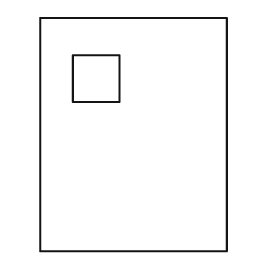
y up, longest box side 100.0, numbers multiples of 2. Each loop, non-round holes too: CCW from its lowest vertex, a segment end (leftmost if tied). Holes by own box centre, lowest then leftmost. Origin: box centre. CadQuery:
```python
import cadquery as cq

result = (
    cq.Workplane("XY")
    .moveTo(-40.0, -50.0)
    .lineTo(40.0, -50.0)
    .lineTo(40.0, 50.0)
    .lineTo(-40.0, 50.0)
    .close()
    .moveTo(-26.0, 14.0)
    .lineTo(-6.0, 14.0)
    .lineTo(-6.0, 34.0)
    .lineTo(-26.0, 34.0)
    .close()
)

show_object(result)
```